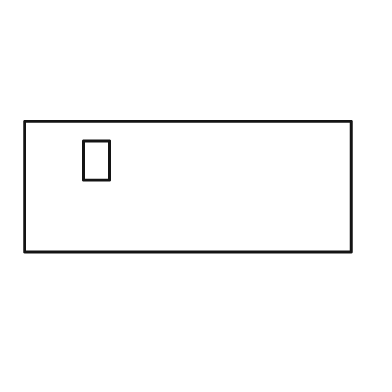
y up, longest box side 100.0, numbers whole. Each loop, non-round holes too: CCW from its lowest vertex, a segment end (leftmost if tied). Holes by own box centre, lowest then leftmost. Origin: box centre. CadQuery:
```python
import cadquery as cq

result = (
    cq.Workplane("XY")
    .moveTo(-50.0, -20.0)
    .lineTo(50.0, -20.0)
    .lineTo(50.0, 20.0)
    .lineTo(-50.0, 20.0)
    .close()
    .moveTo(-32.0, 2.0)
    .lineTo(-24.0, 2.0)
    .lineTo(-24.0, 14.0)
    .lineTo(-32.0, 14.0)
    .close()
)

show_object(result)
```